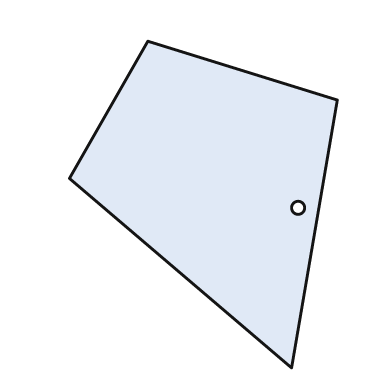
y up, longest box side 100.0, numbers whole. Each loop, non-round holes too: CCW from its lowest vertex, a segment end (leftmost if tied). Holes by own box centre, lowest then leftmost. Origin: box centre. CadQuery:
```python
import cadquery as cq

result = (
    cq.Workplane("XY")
    .moveTo(27.0, -50.0)
    .lineTo(41.0, 32.0)
    .lineTo(-17.0, 50.0)
    .lineTo(-41.0, 8.0)
    .close()
    .moveTo(29.0, -1.0)
    .circle(2.0)
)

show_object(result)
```